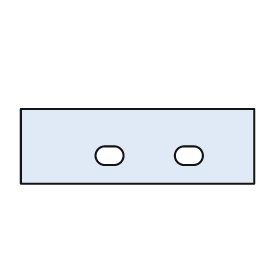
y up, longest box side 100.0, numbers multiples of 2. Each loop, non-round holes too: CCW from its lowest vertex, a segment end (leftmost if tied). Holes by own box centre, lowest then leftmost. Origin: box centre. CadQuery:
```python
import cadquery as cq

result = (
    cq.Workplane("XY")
    .moveTo(-50.0, -16.0)
    .lineTo(50.0, -16.0)
    .lineTo(50.0, 16.0)
    .lineTo(-50.0, 16.0)
    .close()
    .moveTo(-14.0, -8.0)
    .lineTo(-10.0, -8.0)
    .threePointArc((-6.0, -4.0), (-10.0, 0.0))
    .lineTo(-14.0, 0.0)
    .threePointArc((-18.0, -4.0), (-14.0, -8.0))
    .close()
    .moveTo(20.0, -8.0)
    .lineTo(24.0, -8.0)
    .threePointArc((28.0, -4.0), (24.0, 0.0))
    .lineTo(20.0, 0.0)
    .threePointArc((16.0, -4.0), (20.0, -8.0))
    .close()
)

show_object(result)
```